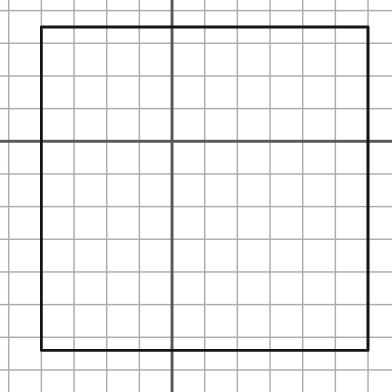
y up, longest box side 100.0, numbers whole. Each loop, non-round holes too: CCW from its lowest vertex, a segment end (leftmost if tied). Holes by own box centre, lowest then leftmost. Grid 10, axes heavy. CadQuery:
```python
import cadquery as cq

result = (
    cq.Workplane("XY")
    .moveTo(-40.0, -64.0)
    .lineTo(60.0, -64.0)
    .lineTo(60.0, 35.0)
    .lineTo(-40.0, 35.0)
    .close()
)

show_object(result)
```